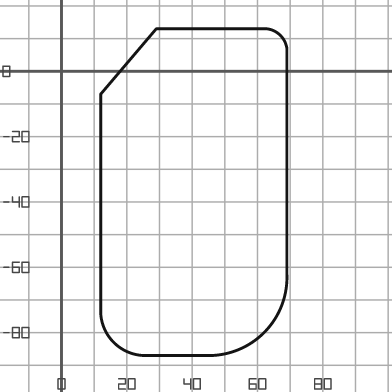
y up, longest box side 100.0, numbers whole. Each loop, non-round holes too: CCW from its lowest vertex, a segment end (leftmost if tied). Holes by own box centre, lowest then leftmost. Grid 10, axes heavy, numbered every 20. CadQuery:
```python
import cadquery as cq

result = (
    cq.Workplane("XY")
    .moveTo(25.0, -87.0)
    .lineTo(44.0, -87.0)
    .threePointArc((62.0, -80.0), (69.0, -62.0))
    .lineTo(69.0, 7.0)
    .threePointArc((67.0, 11.0), (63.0, 13.0))
    .lineTo(29.0, 13.0)
    .lineTo(12.0, -7.0)
    .lineTo(12.0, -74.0)
    .threePointArc((16.0, -83.0), (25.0, -87.0))
    .close()
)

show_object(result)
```